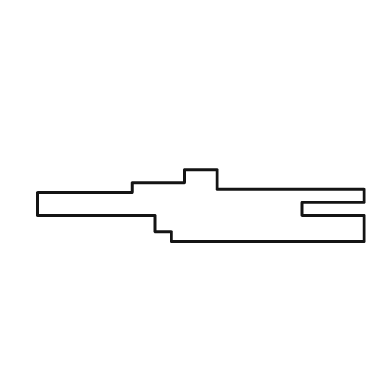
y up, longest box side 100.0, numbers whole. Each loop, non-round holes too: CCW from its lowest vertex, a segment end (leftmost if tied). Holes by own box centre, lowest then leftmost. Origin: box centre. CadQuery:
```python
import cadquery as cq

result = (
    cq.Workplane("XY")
    .moveTo(-9.0, -11.0)
    .lineTo(50.0, -11.0)
    .lineTo(50.0, -3.0)
    .lineTo(31.0, -3.0)
    .lineTo(31.0, 1.0)
    .lineTo(50.0, 1.0)
    .lineTo(50.0, 5.0)
    .lineTo(5.0, 5.0)
    .lineTo(5.0, 11.0)
    .lineTo(-5.0, 11.0)
    .lineTo(-5.0, 7.0)
    .lineTo(-21.0, 7.0)
    .lineTo(-21.0, 4.0)
    .lineTo(-50.0, 4.0)
    .lineTo(-50.0, -3.0)
    .lineTo(-14.0, -3.0)
    .lineTo(-14.0, -8.0)
    .lineTo(-9.0, -8.0)
    .close()
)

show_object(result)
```